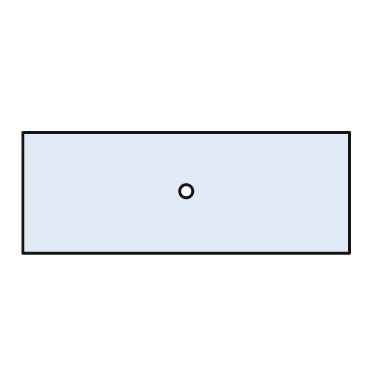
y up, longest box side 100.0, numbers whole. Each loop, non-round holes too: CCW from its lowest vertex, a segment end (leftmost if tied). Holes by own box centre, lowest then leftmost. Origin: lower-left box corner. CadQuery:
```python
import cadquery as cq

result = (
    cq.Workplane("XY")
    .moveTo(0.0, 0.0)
    .lineTo(100.0, 0.0)
    .lineTo(100.0, 37.0)
    .lineTo(0.0, 37.0)
    .close()
    .moveTo(50.0, 19.0)
    .circle(2.0)
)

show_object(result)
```